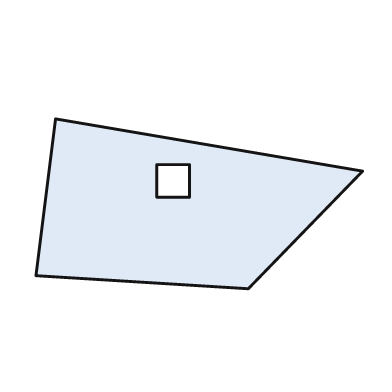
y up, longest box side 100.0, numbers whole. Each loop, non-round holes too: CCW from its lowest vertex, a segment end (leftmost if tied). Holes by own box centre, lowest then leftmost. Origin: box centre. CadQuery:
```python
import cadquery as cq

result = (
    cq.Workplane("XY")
    .moveTo(15.0, -26.0)
    .lineTo(50.0, 10.0)
    .lineTo(-44.0, 26.0)
    .lineTo(-50.0, -22.0)
    .close()
    .moveTo(-13.0, 2.0)
    .lineTo(-3.0, 2.0)
    .lineTo(-3.0, 12.0)
    .lineTo(-13.0, 12.0)
    .close()
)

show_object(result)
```